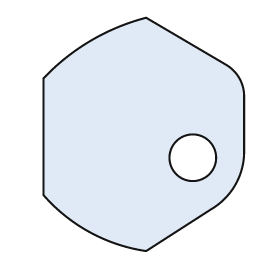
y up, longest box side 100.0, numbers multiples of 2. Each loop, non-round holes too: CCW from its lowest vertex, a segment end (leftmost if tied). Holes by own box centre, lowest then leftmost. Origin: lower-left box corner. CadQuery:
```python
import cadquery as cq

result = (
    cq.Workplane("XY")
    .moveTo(44.0, 0.0)
    .lineTo(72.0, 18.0)
    .threePointArc((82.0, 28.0), (86.0, 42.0))
    .lineTo(86.0, 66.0)
    .threePointArc((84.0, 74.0), (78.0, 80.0))
    .lineTo(44.0, 100.0)
    .threePointArc((20.0, 90.0), (0.0, 74.0))
    .lineTo(0.0, 24.0)
    .threePointArc((20.0, 8.0), (44.0, 0.0))
    .close()
    .moveTo(64.0, 40.0)
    .circle(10.0)
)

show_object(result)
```